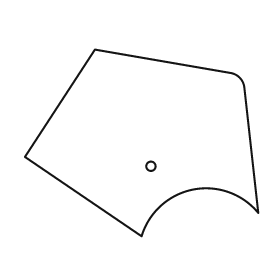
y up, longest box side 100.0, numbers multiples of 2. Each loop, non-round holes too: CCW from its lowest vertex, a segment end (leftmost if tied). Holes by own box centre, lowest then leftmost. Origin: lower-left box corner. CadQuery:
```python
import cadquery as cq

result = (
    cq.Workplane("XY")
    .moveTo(50.0, 0.0)
    .threePointArc((72.0, 20.0), (100.0, 10.0))
    .lineTo(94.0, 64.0)
    .threePointArc((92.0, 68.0), (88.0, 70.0))
    .lineTo(30.0, 80.0)
    .lineTo(0.0, 34.0)
    .close()
    .moveTo(54.0, 30.0)
    .circle(2.0)
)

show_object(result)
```